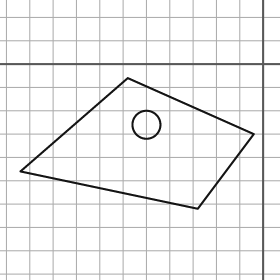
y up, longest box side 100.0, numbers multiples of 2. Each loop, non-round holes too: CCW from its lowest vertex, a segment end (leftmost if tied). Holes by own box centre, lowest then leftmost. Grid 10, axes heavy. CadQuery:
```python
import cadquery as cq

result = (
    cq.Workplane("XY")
    .moveTo(-28.0, -62.0)
    .lineTo(-4.0, -30.0)
    .lineTo(-58.0, -6.0)
    .lineTo(-104.0, -46.0)
    .close()
    .moveTo(-50.0, -26.0)
    .circle(6.0)
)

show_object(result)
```